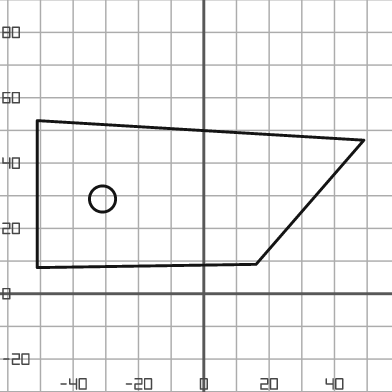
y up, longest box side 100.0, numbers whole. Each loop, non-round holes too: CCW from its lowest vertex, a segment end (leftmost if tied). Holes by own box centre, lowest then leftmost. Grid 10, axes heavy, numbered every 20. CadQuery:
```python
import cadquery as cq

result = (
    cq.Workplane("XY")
    .moveTo(-51.0, 8.0)
    .lineTo(16.0, 9.0)
    .lineTo(49.0, 47.0)
    .lineTo(-51.0, 53.0)
    .close()
    .moveTo(-31.0, 29.0)
    .circle(4.0)
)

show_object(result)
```